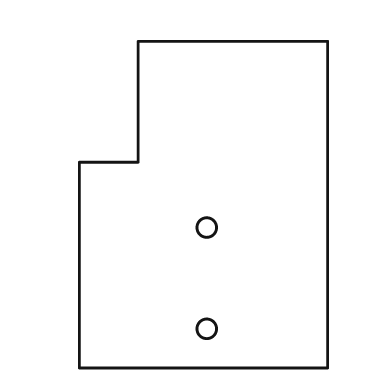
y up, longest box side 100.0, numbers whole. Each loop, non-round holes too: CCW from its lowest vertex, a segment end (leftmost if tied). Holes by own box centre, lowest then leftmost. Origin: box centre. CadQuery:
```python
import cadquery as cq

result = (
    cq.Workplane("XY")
    .moveTo(-38.0, -50.0)
    .lineTo(38.0, -50.0)
    .lineTo(38.0, 50.0)
    .lineTo(-20.0, 50.0)
    .lineTo(-20.0, 13.0)
    .lineTo(-38.0, 13.0)
    .close()
    .moveTo(1.0, -38.0)
    .circle(3.0)
    .moveTo(1.0, -7.0)
    .circle(3.0)
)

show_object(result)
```